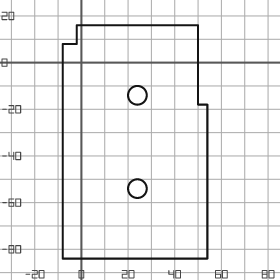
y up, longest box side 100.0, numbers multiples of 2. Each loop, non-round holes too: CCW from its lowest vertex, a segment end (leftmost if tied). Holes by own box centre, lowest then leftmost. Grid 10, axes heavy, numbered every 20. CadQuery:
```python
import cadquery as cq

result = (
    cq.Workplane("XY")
    .moveTo(-8.0, -84.0)
    .lineTo(54.0, -84.0)
    .lineTo(54.0, -18.0)
    .lineTo(50.0, -18.0)
    .lineTo(50.0, 16.0)
    .lineTo(-2.0, 16.0)
    .lineTo(-2.0, 8.0)
    .lineTo(-8.0, 8.0)
    .close()
    .moveTo(24.0, -54.0)
    .circle(4.0)
    .moveTo(24.0, -14.0)
    .circle(4.0)
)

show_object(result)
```